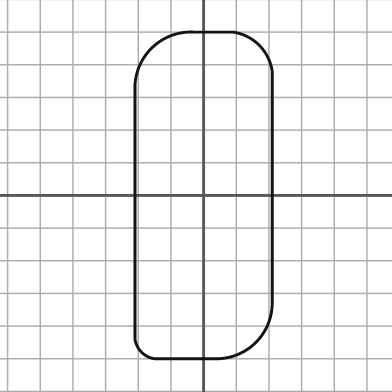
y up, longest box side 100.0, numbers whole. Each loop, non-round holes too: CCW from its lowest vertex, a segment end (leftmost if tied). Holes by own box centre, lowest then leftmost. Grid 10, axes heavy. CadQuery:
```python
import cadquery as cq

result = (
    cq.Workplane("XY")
    .moveTo(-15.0, -50.0)
    .lineTo(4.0, -50.0)
    .threePointArc((16.0, -45.0), (21.0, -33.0))
    .lineTo(21.0, 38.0)
    .threePointArc((17.0, 46.0), (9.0, 50.0))
    .lineTo(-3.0, 50.0)
    .threePointArc((-16.0, 45.0), (-21.0, 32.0))
    .lineTo(-21.0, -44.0)
    .threePointArc((-19.0, -48.0), (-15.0, -50.0))
    .close()
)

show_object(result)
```